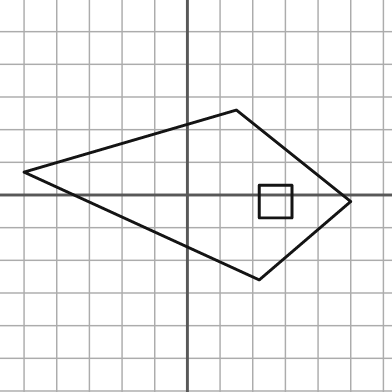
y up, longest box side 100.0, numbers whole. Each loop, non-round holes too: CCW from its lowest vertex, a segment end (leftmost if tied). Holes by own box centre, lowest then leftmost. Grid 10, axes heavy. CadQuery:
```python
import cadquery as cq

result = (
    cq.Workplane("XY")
    .moveTo(22.0, -26.0)
    .lineTo(50.0, -2.0)
    .lineTo(15.0, 26.0)
    .lineTo(-50.0, 7.0)
    .close()
    .moveTo(22.0, -7.0)
    .lineTo(32.0, -7.0)
    .lineTo(32.0, 3.0)
    .lineTo(22.0, 3.0)
    .close()
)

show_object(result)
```